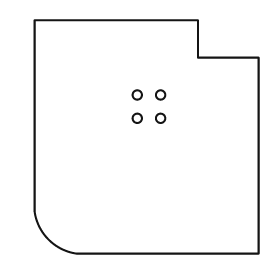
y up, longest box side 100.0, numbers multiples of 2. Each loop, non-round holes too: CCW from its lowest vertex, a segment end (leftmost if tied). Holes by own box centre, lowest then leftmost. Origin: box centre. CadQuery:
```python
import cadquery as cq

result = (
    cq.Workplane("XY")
    .moveTo(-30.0, -50.0)
    .lineTo(48.0, -50.0)
    .lineTo(48.0, 34.0)
    .lineTo(22.0, 34.0)
    .lineTo(22.0, 50.0)
    .lineTo(-48.0, 50.0)
    .lineTo(-48.0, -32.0)
    .threePointArc((-42.0, -44.0), (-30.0, -50.0))
    .close()
    .moveTo(-4.0, 8.0)
    .circle(2.0)
    .moveTo(6.0, 8.0)
    .circle(2.0)
    .moveTo(-4.0, 18.0)
    .circle(2.0)
    .moveTo(6.0, 18.0)
    .circle(2.0)
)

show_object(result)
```